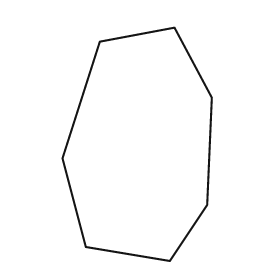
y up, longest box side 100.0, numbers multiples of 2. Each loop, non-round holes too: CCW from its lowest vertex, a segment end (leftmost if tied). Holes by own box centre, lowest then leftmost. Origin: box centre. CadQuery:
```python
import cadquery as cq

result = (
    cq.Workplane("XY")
    .moveTo(14.0, -50.0)
    .lineTo(30.0, -26.0)
    .lineTo(32.0, 20.0)
    .lineTo(16.0, 50.0)
    .lineTo(-16.0, 44.0)
    .lineTo(-32.0, -6.0)
    .lineTo(-22.0, -44.0)
    .close()
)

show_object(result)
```